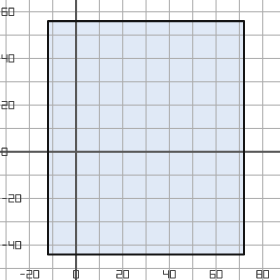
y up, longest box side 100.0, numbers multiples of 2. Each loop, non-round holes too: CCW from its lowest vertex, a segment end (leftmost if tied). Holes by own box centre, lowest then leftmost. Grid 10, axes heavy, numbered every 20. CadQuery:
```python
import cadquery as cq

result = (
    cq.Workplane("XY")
    .moveTo(-12.0, -44.0)
    .lineTo(72.0, -44.0)
    .lineTo(72.0, 56.0)
    .lineTo(-12.0, 56.0)
    .close()
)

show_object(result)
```